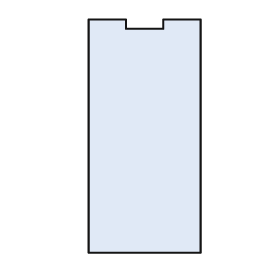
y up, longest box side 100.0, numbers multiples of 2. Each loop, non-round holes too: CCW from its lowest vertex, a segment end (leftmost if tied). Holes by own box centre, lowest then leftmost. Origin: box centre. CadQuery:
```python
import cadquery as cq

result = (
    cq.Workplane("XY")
    .moveTo(-24.0, -50.0)
    .lineTo(24.0, -50.0)
    .lineTo(24.0, 50.0)
    .lineTo(8.0, 50.0)
    .lineTo(8.0, 46.0)
    .lineTo(-8.0, 46.0)
    .lineTo(-8.0, 50.0)
    .lineTo(-24.0, 50.0)
    .close()
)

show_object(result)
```